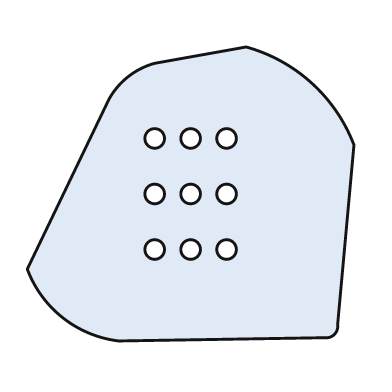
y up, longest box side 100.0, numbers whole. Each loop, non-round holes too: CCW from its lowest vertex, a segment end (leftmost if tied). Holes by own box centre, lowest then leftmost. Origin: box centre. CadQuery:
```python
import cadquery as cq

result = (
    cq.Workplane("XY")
    .moveTo(-22.0, -45.0)
    .lineTo(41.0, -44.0)
    .threePointArc((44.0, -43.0), (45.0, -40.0))
    .lineTo(50.0, 15.0)
    .threePointArc((37.0, 34.0), (17.0, 45.0))
    .lineTo(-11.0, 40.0)
    .threePointArc((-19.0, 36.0), (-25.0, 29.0))
    .lineTo(-50.0, -23.0)
    .threePointArc((-39.0, -38.0), (-22.0, -45.0))
    .close()
    .moveTo(-11.0, -17.0)
    .circle(3.0)
    .moveTo(0.0, -17.0)
    .circle(3.0)
    .moveTo(11.0, -17.0)
    .circle(3.0)
    .moveTo(-11.0, 0.0)
    .circle(3.0)
    .moveTo(0.0, 0.0)
    .circle(3.0)
    .moveTo(11.0, 0.0)
    .circle(3.0)
    .moveTo(-11.0, 17.0)
    .circle(3.0)
    .moveTo(0.0, 17.0)
    .circle(3.0)
    .moveTo(11.0, 17.0)
    .circle(3.0)
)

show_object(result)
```